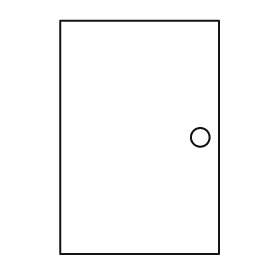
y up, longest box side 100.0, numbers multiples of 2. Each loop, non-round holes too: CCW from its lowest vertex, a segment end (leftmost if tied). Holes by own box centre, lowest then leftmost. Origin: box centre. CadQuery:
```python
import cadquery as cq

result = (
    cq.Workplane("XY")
    .moveTo(-34.0, -50.0)
    .lineTo(34.0, -50.0)
    .lineTo(34.0, 50.0)
    .lineTo(-34.0, 50.0)
    .close()
    .moveTo(26.0, 0.0)
    .circle(4.0)
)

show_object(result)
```